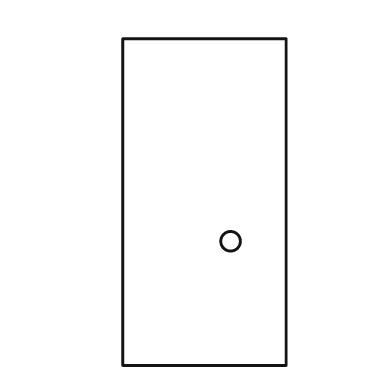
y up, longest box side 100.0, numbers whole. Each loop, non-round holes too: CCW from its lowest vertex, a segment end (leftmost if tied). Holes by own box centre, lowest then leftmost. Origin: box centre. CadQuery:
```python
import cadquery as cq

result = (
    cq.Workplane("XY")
    .moveTo(-25.0, -50.0)
    .lineTo(25.0, -50.0)
    .lineTo(25.0, 50.0)
    .lineTo(-25.0, 50.0)
    .close()
    .moveTo(8.0, -12.0)
    .circle(3.0)
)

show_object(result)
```